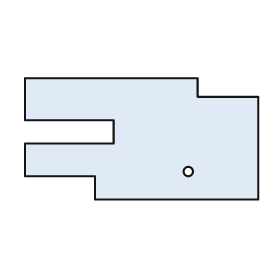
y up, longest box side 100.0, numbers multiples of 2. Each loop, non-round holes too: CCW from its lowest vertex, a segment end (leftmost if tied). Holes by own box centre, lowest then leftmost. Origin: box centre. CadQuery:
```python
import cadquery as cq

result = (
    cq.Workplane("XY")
    .moveTo(-20.0, -26.0)
    .lineTo(50.0, -26.0)
    .lineTo(50.0, 18.0)
    .lineTo(24.0, 18.0)
    .lineTo(24.0, 26.0)
    .lineTo(-50.0, 26.0)
    .lineTo(-50.0, 8.0)
    .lineTo(-12.0, 8.0)
    .lineTo(-12.0, -2.0)
    .lineTo(-50.0, -2.0)
    .lineTo(-50.0, -16.0)
    .lineTo(-20.0, -16.0)
    .close()
    .moveTo(20.0, -14.0)
    .circle(2.0)
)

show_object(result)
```